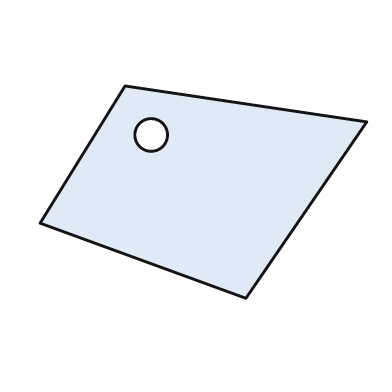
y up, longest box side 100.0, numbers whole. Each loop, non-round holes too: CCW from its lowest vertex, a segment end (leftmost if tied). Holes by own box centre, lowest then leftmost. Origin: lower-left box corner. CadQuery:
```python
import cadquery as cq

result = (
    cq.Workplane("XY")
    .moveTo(63.0, 0.0)
    .lineTo(100.0, 54.0)
    .lineTo(26.0, 65.0)
    .lineTo(0.0, 23.0)
    .close()
    .moveTo(34.0, 50.0)
    .circle(5.0)
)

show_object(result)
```